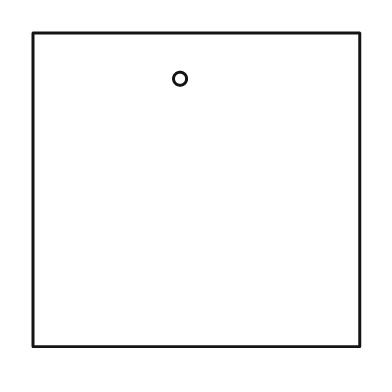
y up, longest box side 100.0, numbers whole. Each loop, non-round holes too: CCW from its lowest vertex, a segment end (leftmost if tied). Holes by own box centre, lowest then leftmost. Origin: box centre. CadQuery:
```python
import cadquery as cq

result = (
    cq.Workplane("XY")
    .moveTo(-50.0, -48.0)
    .lineTo(50.0, -48.0)
    .lineTo(50.0, 48.0)
    .lineTo(-50.0, 48.0)
    .close()
    .moveTo(-5.0, 34.0)
    .circle(2.0)
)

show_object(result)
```